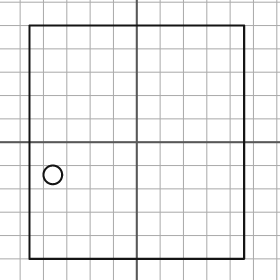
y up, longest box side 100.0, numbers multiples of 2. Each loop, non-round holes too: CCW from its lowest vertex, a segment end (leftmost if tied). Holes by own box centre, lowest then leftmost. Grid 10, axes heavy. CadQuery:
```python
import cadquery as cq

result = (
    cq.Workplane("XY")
    .moveTo(-46.0, -50.0)
    .lineTo(46.0, -50.0)
    .lineTo(46.0, 50.0)
    .lineTo(-46.0, 50.0)
    .close()
    .moveTo(-36.0, -14.0)
    .circle(4.0)
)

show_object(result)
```